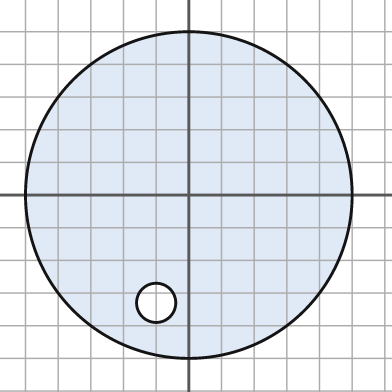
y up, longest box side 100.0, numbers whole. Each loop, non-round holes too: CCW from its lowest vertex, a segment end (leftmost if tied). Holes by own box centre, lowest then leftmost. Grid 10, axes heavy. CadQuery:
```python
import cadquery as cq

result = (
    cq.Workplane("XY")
    .moveTo(0.0, 0.0)
    .circle(50.0)
    .moveTo(-10.0, -33.0)
    .circle(6.0)
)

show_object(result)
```